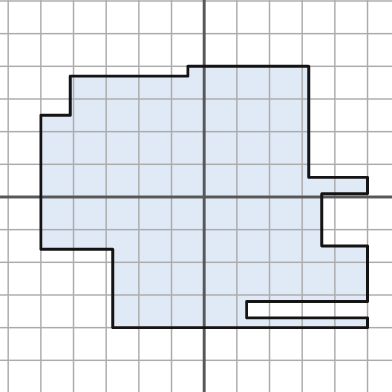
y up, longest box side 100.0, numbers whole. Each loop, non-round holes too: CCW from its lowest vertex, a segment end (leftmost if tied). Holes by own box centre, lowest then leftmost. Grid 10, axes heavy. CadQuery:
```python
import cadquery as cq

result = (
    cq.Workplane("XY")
    .moveTo(-28.0, -40.0)
    .lineTo(50.0, -40.0)
    .lineTo(50.0, -37.0)
    .lineTo(13.0, -37.0)
    .lineTo(13.0, -32.0)
    .lineTo(50.0, -32.0)
    .lineTo(50.0, -15.0)
    .lineTo(36.0, -15.0)
    .lineTo(36.0, 1.0)
    .lineTo(50.0, 1.0)
    .lineTo(50.0, 6.0)
    .lineTo(32.0, 6.0)
    .lineTo(32.0, 40.0)
    .lineTo(-5.0, 40.0)
    .lineTo(-5.0, 37.0)
    .lineTo(-41.0, 37.0)
    .lineTo(-41.0, 25.0)
    .lineTo(-50.0, 25.0)
    .lineTo(-50.0, -16.0)
    .lineTo(-28.0, -16.0)
    .close()
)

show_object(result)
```